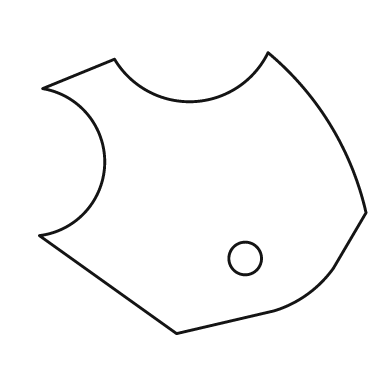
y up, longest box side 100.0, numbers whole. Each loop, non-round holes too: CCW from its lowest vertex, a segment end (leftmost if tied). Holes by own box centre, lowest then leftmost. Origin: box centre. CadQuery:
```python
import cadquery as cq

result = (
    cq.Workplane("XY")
    .moveTo(-8.0, -43.0)
    .lineTo(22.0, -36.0)
    .threePointArc((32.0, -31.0), (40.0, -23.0))
    .lineTo(50.0, -6.0)
    .threePointArc((39.0, 21.0), (20.0, 43.0))
    .threePointArc((-3.0, 28.0), (-27.0, 41.0))
    .lineTo(-49.0, 32.0)
    .threePointArc((-30.0, 9.0), (-50.0, -13.0))
    .close()
    .moveTo(13.0, -20.0)
    .circle(5.0)
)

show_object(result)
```